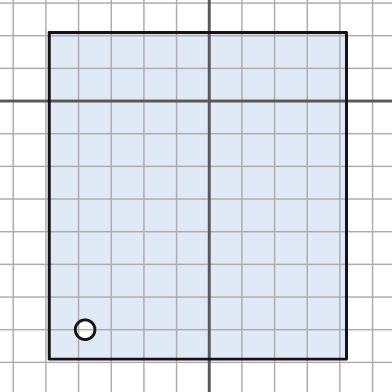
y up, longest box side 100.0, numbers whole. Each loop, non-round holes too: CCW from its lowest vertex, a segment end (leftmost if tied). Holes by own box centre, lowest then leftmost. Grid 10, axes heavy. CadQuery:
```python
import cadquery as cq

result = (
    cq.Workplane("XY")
    .moveTo(-49.0, -79.0)
    .lineTo(42.0, -79.0)
    .lineTo(42.0, 21.0)
    .lineTo(-49.0, 21.0)
    .close()
    .moveTo(-38.0, -70.0)
    .circle(3.0)
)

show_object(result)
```